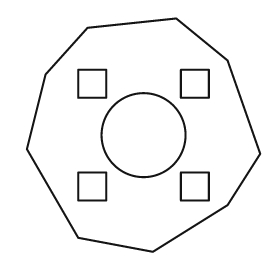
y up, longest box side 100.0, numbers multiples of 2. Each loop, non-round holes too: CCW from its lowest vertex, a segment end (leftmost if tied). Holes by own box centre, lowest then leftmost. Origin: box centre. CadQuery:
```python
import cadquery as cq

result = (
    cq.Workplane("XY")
    .moveTo(4.0, -50.0)
    .lineTo(36.0, -30.0)
    .lineTo(50.0, -8.0)
    .lineTo(36.0, 32.0)
    .lineTo(14.0, 50.0)
    .lineTo(-24.0, 46.0)
    .lineTo(-42.0, 26.0)
    .lineTo(-50.0, -6.0)
    .lineTo(-28.0, -44.0)
    .close()
    .moveTo(-28.0, -28.0)
    .lineTo(-16.0, -28.0)
    .lineTo(-16.0, -16.0)
    .lineTo(-28.0, -16.0)
    .close()
    .moveTo(16.0, -28.0)
    .lineTo(28.0, -28.0)
    .lineTo(28.0, -16.0)
    .lineTo(16.0, -16.0)
    .close()
    .moveTo(0.0, 0.0)
    .circle(18.0)
    .moveTo(-28.0, 16.0)
    .lineTo(-16.0, 16.0)
    .lineTo(-16.0, 28.0)
    .lineTo(-28.0, 28.0)
    .close()
    .moveTo(16.0, 16.0)
    .lineTo(28.0, 16.0)
    .lineTo(28.0, 28.0)
    .lineTo(16.0, 28.0)
    .close()
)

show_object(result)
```